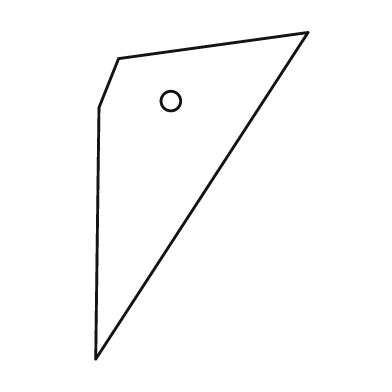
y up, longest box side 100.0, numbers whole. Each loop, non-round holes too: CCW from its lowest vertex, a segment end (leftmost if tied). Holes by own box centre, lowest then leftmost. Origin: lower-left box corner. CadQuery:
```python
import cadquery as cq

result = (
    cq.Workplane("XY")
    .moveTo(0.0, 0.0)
    .lineTo(65.0, 100.0)
    .lineTo(7.0, 92.0)
    .lineTo(1.0, 77.0)
    .close()
    .moveTo(23.0, 79.0)
    .circle(3.0)
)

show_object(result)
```